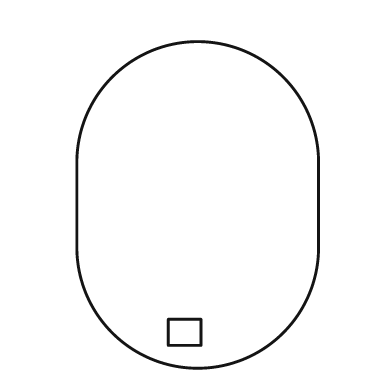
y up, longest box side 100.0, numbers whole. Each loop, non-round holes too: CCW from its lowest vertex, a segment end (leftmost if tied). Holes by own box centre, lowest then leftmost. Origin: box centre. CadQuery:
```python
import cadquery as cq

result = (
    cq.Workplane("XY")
    .moveTo(-37.0, -13.0)
    .threePointArc((0.0, -50.0), (37.0, -13.0))
    .lineTo(37.0, 13.0)
    .threePointArc((0.0, 50.0), (-37.0, 13.0))
    .close()
    .moveTo(-9.0, -43.0)
    .lineTo(1.0, -43.0)
    .lineTo(1.0, -35.0)
    .lineTo(-9.0, -35.0)
    .close()
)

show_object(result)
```